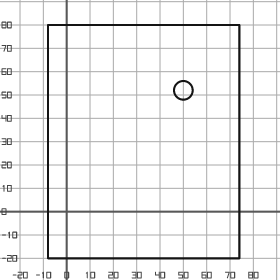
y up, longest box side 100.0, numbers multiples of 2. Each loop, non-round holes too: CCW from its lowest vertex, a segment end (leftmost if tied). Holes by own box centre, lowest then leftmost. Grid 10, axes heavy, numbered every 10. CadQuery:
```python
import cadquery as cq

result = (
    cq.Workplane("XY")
    .moveTo(-8.0, -20.0)
    .lineTo(74.0, -20.0)
    .lineTo(74.0, 80.0)
    .lineTo(-8.0, 80.0)
    .close()
    .moveTo(50.0, 52.0)
    .circle(4.0)
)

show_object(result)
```